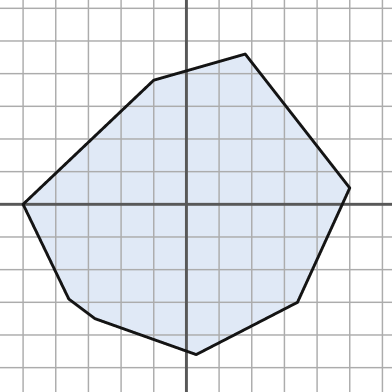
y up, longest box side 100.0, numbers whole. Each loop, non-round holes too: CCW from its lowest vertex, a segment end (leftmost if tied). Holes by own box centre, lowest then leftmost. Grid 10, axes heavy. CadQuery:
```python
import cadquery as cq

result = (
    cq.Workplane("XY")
    .moveTo(3.0, -46.0)
    .lineTo(34.0, -30.0)
    .lineTo(50.0, 5.0)
    .lineTo(18.0, 46.0)
    .lineTo(-10.0, 38.0)
    .lineTo(-50.0, 0.0)
    .lineTo(-36.0, -29.0)
    .lineTo(-28.0, -35.0)
    .close()
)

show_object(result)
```